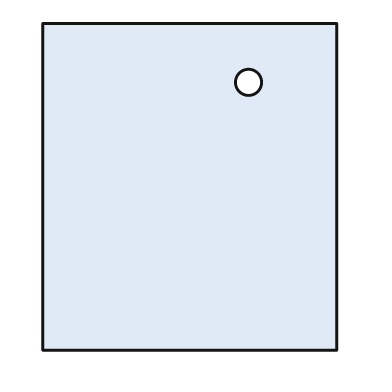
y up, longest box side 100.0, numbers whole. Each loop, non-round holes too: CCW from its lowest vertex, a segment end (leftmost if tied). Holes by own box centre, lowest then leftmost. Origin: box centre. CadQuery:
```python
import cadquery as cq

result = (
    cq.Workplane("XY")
    .moveTo(-45.0, -50.0)
    .lineTo(45.0, -50.0)
    .lineTo(45.0, 50.0)
    .lineTo(-45.0, 50.0)
    .close()
    .moveTo(18.0, 32.0)
    .circle(4.0)
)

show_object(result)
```